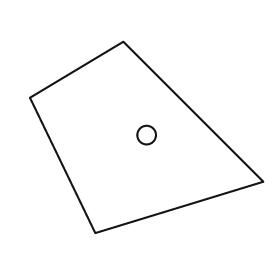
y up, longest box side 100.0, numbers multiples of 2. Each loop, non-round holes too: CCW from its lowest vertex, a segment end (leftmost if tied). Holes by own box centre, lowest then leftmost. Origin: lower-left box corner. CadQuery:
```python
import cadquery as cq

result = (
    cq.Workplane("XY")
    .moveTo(28.0, 0.0)
    .lineTo(100.0, 22.0)
    .lineTo(40.0, 82.0)
    .lineTo(0.0, 58.0)
    .close()
    .moveTo(50.0, 42.0)
    .circle(4.0)
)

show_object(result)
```